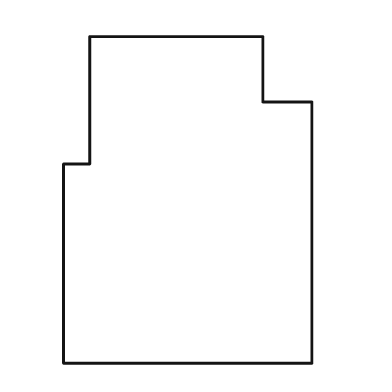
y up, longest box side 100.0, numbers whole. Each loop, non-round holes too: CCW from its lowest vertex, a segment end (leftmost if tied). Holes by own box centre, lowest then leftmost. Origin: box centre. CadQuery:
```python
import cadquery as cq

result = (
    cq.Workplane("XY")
    .moveTo(-38.0, -50.0)
    .lineTo(38.0, -50.0)
    .lineTo(38.0, 30.0)
    .lineTo(23.0, 30.0)
    .lineTo(23.0, 50.0)
    .lineTo(-30.0, 50.0)
    .lineTo(-30.0, 11.0)
    .lineTo(-38.0, 11.0)
    .close()
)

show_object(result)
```